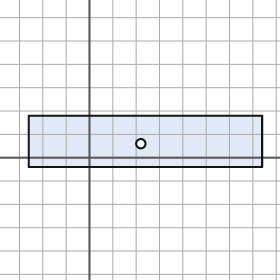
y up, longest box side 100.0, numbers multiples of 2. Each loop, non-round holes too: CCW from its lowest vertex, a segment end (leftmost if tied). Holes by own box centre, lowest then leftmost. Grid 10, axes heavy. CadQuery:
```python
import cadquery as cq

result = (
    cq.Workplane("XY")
    .moveTo(-26.0, -4.0)
    .lineTo(74.0, -4.0)
    .lineTo(74.0, 18.0)
    .lineTo(-26.0, 18.0)
    .close()
    .moveTo(22.0, 6.0)
    .circle(2.0)
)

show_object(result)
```